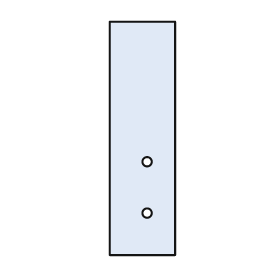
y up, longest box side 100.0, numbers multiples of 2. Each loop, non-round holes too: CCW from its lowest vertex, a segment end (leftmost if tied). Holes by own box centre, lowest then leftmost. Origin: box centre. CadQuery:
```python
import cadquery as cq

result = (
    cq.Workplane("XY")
    .moveTo(-14.0, -50.0)
    .lineTo(14.0, -50.0)
    .lineTo(14.0, 50.0)
    .lineTo(-14.0, 50.0)
    .close()
    .moveTo(2.0, -32.0)
    .circle(2.0)
    .moveTo(2.0, -10.0)
    .circle(2.0)
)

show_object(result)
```